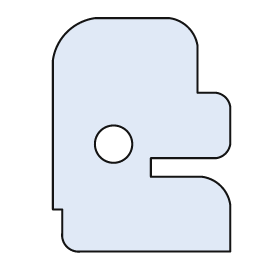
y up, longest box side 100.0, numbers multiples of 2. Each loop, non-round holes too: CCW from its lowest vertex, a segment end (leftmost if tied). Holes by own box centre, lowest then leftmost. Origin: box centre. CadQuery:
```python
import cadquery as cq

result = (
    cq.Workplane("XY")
    .moveTo(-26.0, -50.0)
    .lineTo(38.0, -50.0)
    .lineTo(38.0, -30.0)
    .threePointArc((34.0, -22.0), (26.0, -18.0))
    .lineTo(4.0, -18.0)
    .lineTo(4.0, -10.0)
    .lineTo(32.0, -10.0)
    .threePointArc((36.0, -8.0), (38.0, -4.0))
    .lineTo(38.0, 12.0)
    .threePointArc((36.0, 16.0), (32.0, 18.0))
    .lineTo(24.0, 18.0)
    .lineTo(24.0, 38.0)
    .threePointArc((20.0, 46.0), (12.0, 50.0))
    .lineTo(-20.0, 50.0)
    .threePointArc((-32.0, 44.0), (-38.0, 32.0))
    .lineTo(-38.0, -32.0)
    .lineTo(-34.0, -32.0)
    .lineTo(-34.0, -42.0)
    .threePointArc((-32.0, -48.0), (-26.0, -50.0))
    .close()
    .moveTo(-12.0, -4.0)
    .circle(8.0)
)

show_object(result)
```